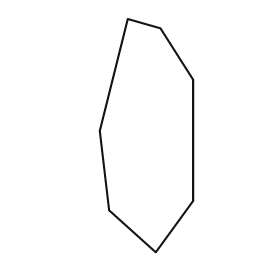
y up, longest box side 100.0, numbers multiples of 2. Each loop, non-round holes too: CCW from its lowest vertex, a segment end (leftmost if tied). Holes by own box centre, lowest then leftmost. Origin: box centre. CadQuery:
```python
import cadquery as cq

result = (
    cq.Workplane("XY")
    .moveTo(4.0, -50.0)
    .lineTo(20.0, -28.0)
    .lineTo(20.0, 24.0)
    .lineTo(6.0, 46.0)
    .lineTo(-8.0, 50.0)
    .lineTo(-20.0, 2.0)
    .lineTo(-16.0, -32.0)
    .close()
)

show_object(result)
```